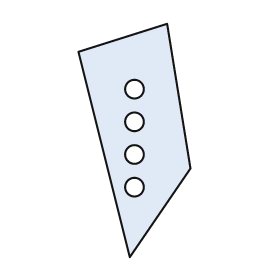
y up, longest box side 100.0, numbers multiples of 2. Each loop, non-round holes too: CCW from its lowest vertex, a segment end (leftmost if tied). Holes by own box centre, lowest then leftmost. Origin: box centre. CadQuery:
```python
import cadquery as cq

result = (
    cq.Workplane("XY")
    .moveTo(-2.0, -50.0)
    .lineTo(24.0, -12.0)
    .lineTo(14.0, 50.0)
    .lineTo(-24.0, 38.0)
    .close()
    .moveTo(0.0, -20.0)
    .circle(4.0)
    .moveTo(0.0, -6.0)
    .circle(4.0)
    .moveTo(0.0, 8.0)
    .circle(4.0)
    .moveTo(0.0, 22.0)
    .circle(4.0)
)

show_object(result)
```